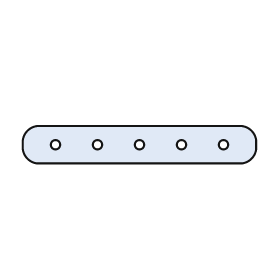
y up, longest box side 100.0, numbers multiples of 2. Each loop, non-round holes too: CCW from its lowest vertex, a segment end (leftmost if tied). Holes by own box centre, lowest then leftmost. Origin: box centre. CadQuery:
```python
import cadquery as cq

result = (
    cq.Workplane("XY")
    .moveTo(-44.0, -8.0)
    .lineTo(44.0, -8.0)
    .threePointArc((48.0, -6.0), (50.0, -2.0))
    .lineTo(50.0, 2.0)
    .threePointArc((48.0, 6.0), (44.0, 8.0))
    .lineTo(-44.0, 8.0)
    .threePointArc((-48.0, 6.0), (-50.0, 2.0))
    .lineTo(-50.0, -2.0)
    .threePointArc((-48.0, -6.0), (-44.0, -8.0))
    .close()
    .moveTo(-36.0, 0.0)
    .circle(2.0)
    .moveTo(-18.0, 0.0)
    .circle(2.0)
    .moveTo(0.0, 0.0)
    .circle(2.0)
    .moveTo(18.0, 0.0)
    .circle(2.0)
    .moveTo(36.0, 0.0)
    .circle(2.0)
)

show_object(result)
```